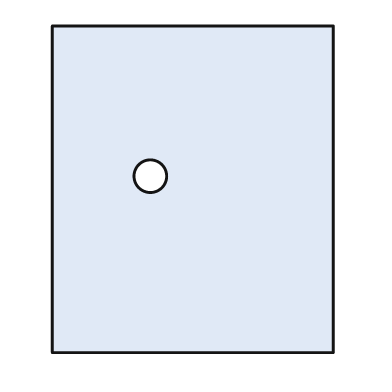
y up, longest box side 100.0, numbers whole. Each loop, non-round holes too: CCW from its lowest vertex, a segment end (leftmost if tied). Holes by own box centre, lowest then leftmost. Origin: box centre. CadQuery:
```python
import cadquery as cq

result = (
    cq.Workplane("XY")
    .moveTo(-43.0, -50.0)
    .lineTo(43.0, -50.0)
    .lineTo(43.0, 50.0)
    .lineTo(-43.0, 50.0)
    .close()
    .moveTo(-13.0, 4.0)
    .circle(5.0)
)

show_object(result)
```